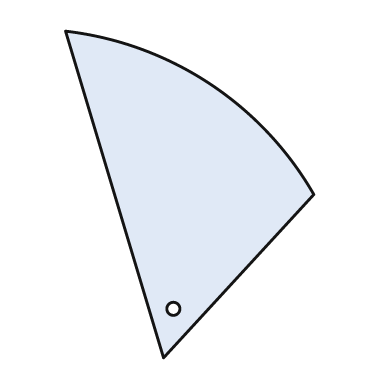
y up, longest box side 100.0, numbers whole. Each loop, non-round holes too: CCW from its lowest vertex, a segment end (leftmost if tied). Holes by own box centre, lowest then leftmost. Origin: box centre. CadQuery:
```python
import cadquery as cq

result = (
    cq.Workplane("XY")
    .moveTo(-8.0, -50.0)
    .lineTo(38.0, 0.0)
    .threePointArc((6.0, 34.0), (-38.0, 50.0))
    .close()
    .moveTo(-5.0, -35.0)
    .circle(2.0)
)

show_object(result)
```